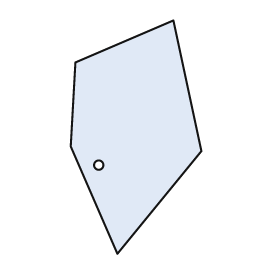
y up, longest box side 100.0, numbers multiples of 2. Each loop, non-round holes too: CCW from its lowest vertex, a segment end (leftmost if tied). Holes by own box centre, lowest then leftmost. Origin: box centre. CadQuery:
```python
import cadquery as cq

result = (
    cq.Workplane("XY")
    .moveTo(-8.0, -50.0)
    .lineTo(28.0, -6.0)
    .lineTo(16.0, 50.0)
    .lineTo(-26.0, 32.0)
    .lineTo(-28.0, -4.0)
    .close()
    .moveTo(-16.0, -12.0)
    .circle(2.0)
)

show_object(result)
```